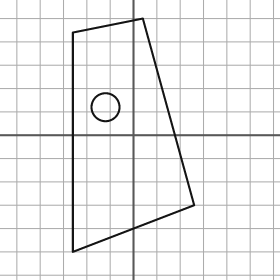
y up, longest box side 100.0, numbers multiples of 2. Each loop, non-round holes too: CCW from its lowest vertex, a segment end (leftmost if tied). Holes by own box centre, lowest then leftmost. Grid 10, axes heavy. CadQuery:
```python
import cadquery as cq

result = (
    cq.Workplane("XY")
    .moveTo(-26.0, -50.0)
    .lineTo(26.0, -30.0)
    .lineTo(4.0, 50.0)
    .lineTo(-26.0, 44.0)
    .close()
    .moveTo(-12.0, 12.0)
    .circle(6.0)
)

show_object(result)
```